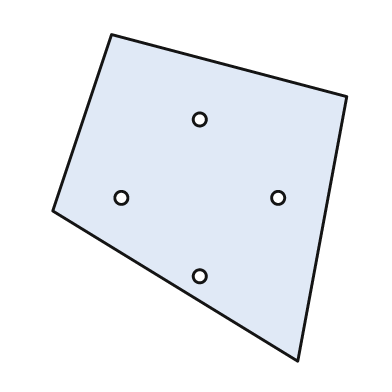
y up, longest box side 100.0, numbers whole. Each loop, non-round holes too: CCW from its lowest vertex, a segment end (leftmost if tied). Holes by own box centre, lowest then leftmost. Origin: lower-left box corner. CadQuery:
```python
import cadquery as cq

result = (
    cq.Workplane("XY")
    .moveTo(75.0, 0.0)
    .lineTo(90.0, 81.0)
    .lineTo(18.0, 100.0)
    .lineTo(0.0, 46.0)
    .close()
    .moveTo(45.0, 26.0)
    .circle(2.0)
    .moveTo(21.0, 50.0)
    .circle(2.0)
    .moveTo(69.0, 50.0)
    .circle(2.0)
    .moveTo(45.0, 74.0)
    .circle(2.0)
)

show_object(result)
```